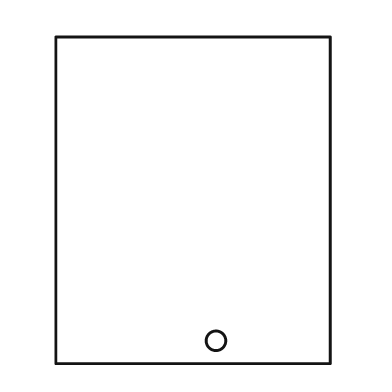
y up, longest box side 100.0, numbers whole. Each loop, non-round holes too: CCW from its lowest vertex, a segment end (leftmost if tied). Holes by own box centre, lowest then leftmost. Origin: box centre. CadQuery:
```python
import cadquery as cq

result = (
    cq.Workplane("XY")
    .moveTo(-42.0, -50.0)
    .lineTo(42.0, -50.0)
    .lineTo(42.0, 50.0)
    .lineTo(-42.0, 50.0)
    .close()
    .moveTo(7.0, -43.0)
    .circle(3.0)
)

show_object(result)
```